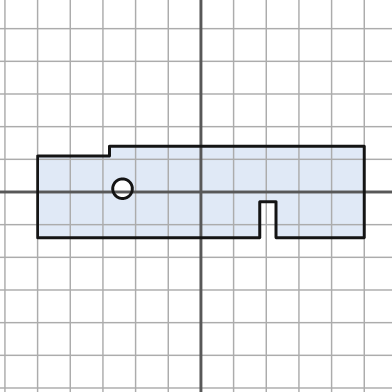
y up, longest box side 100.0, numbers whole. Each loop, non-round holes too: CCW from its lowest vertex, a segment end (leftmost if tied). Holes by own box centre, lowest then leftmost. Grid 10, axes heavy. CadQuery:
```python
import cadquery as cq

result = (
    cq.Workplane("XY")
    .moveTo(-50.0, -14.0)
    .lineTo(18.0, -14.0)
    .lineTo(18.0, -3.0)
    .lineTo(23.0, -3.0)
    .lineTo(23.0, -14.0)
    .lineTo(50.0, -14.0)
    .lineTo(50.0, 14.0)
    .lineTo(-28.0, 14.0)
    .lineTo(-28.0, 11.0)
    .lineTo(-50.0, 11.0)
    .close()
    .moveTo(-24.0, 1.0)
    .circle(3.0)
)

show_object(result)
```